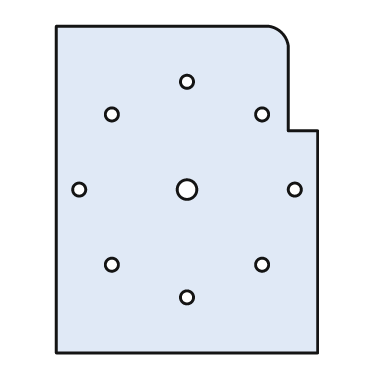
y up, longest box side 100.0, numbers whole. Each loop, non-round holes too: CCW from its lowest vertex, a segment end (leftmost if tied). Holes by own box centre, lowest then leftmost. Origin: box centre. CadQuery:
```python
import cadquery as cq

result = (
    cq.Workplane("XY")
    .moveTo(-40.0, -50.0)
    .lineTo(40.0, -50.0)
    .lineTo(40.0, 18.0)
    .lineTo(31.0, 18.0)
    .lineTo(31.0, 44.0)
    .threePointArc((29.0, 48.0), (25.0, 50.0))
    .lineTo(-40.0, 50.0)
    .close()
    .moveTo(0.0, -33.0)
    .circle(2.0)
    .moveTo(-23.0, -23.0)
    .circle(2.0)
    .moveTo(23.0, -23.0)
    .circle(2.0)
    .moveTo(-33.0, 0.0)
    .circle(2.0)
    .moveTo(0.0, 0.0)
    .circle(3.0)
    .moveTo(33.0, 0.0)
    .circle(2.0)
    .moveTo(-23.0, 23.0)
    .circle(2.0)
    .moveTo(23.0, 23.0)
    .circle(2.0)
    .moveTo(0.0, 33.0)
    .circle(2.0)
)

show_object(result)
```